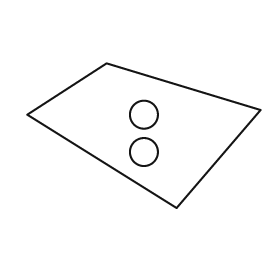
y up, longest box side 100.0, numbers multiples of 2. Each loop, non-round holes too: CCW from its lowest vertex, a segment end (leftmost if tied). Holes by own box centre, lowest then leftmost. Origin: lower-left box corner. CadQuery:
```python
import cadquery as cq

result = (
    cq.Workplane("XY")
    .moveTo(64.0, 0.0)
    .lineTo(100.0, 42.0)
    .lineTo(34.0, 62.0)
    .lineTo(0.0, 40.0)
    .close()
    .moveTo(50.0, 24.0)
    .circle(6.0)
    .moveTo(50.0, 40.0)
    .circle(6.0)
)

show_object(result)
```